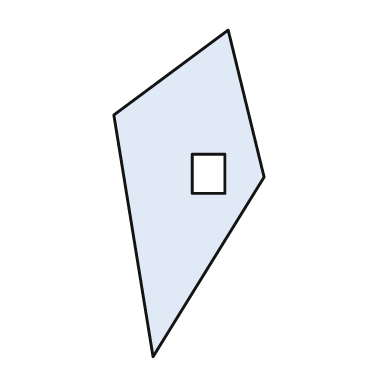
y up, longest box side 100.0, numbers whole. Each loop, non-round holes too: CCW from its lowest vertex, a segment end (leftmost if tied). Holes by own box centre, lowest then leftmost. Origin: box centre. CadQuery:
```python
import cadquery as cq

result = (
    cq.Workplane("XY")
    .moveTo(-11.0, -50.0)
    .lineTo(23.0, 5.0)
    .lineTo(12.0, 50.0)
    .lineTo(-23.0, 24.0)
    .close()
    .moveTo(1.0, 0.0)
    .lineTo(11.0, 0.0)
    .lineTo(11.0, 12.0)
    .lineTo(1.0, 12.0)
    .close()
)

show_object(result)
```